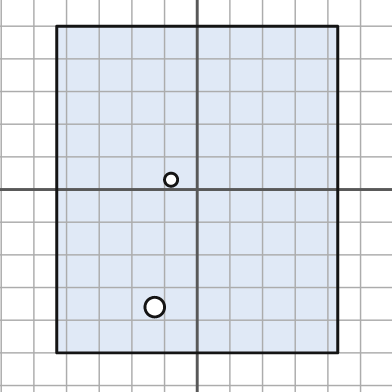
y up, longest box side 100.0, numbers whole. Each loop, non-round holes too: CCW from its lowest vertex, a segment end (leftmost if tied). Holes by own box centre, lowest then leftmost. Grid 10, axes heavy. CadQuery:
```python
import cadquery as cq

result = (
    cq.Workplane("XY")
    .moveTo(-43.0, -50.0)
    .lineTo(43.0, -50.0)
    .lineTo(43.0, 50.0)
    .lineTo(-43.0, 50.0)
    .close()
    .moveTo(-13.0, -36.0)
    .circle(3.0)
    .moveTo(-8.0, 3.0)
    .circle(2.0)
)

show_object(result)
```